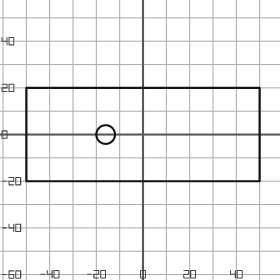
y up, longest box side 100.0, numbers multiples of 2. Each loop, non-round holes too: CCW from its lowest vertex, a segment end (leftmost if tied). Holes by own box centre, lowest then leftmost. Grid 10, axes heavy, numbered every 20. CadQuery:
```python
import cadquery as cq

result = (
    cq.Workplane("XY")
    .moveTo(-50.0, -20.0)
    .lineTo(50.0, -20.0)
    .lineTo(50.0, 20.0)
    .lineTo(-50.0, 20.0)
    .close()
    .moveTo(-16.0, 0.0)
    .circle(4.0)
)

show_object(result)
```